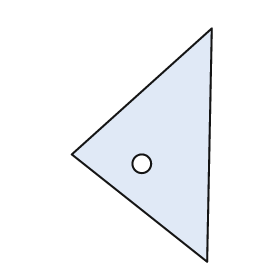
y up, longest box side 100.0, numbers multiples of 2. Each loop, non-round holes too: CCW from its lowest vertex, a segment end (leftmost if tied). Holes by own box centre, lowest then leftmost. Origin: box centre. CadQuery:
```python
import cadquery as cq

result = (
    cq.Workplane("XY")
    .moveTo(28.0, -50.0)
    .lineTo(30.0, 50.0)
    .lineTo(-30.0, -4.0)
    .close()
    .moveTo(0.0, -8.0)
    .circle(4.0)
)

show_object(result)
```